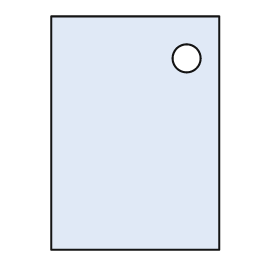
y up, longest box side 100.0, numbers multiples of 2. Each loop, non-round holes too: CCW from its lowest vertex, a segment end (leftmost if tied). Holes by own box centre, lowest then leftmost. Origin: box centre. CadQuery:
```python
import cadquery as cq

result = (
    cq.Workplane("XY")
    .moveTo(-36.0, -50.0)
    .lineTo(36.0, -50.0)
    .lineTo(36.0, 50.0)
    .lineTo(-36.0, 50.0)
    .close()
    .moveTo(22.0, 32.0)
    .circle(6.0)
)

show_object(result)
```